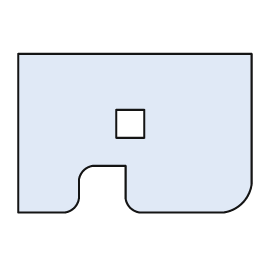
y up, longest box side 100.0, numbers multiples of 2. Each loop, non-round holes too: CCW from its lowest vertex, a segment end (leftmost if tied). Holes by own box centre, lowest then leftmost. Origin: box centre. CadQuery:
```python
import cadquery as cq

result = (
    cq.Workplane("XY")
    .moveTo(-50.0, -34.0)
    .lineTo(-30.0, -34.0)
    .threePointArc((-26.0, -32.0), (-24.0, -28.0))
    .lineTo(-24.0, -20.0)
    .threePointArc((-22.0, -16.0), (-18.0, -14.0))
    .lineTo(-4.0, -14.0)
    .lineTo(-4.0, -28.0)
    .threePointArc((-2.0, -32.0), (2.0, -34.0))
    .lineTo(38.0, -34.0)
    .threePointArc((46.0, -30.0), (50.0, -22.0))
    .lineTo(50.0, 34.0)
    .lineTo(-50.0, 34.0)
    .close()
    .moveTo(-8.0, -2.0)
    .lineTo(4.0, -2.0)
    .lineTo(4.0, 10.0)
    .lineTo(-8.0, 10.0)
    .close()
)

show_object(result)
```